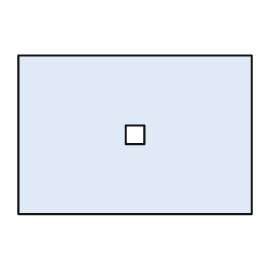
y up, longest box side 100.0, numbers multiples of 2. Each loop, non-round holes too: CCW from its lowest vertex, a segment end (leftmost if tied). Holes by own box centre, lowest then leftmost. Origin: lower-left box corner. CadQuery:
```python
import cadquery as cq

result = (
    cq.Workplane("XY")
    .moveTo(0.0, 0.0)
    .lineTo(100.0, 0.0)
    .lineTo(100.0, 68.0)
    .lineTo(0.0, 68.0)
    .close()
    .moveTo(46.0, 30.0)
    .lineTo(54.0, 30.0)
    .lineTo(54.0, 38.0)
    .lineTo(46.0, 38.0)
    .close()
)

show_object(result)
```